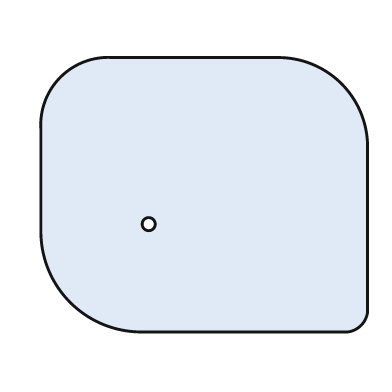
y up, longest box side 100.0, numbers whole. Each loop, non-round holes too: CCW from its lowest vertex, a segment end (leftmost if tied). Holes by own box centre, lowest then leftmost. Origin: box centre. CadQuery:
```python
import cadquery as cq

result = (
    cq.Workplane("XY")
    .moveTo(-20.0, -42.0)
    .lineTo(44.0, -42.0)
    .threePointArc((48.0, -40.0), (50.0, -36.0))
    .lineTo(50.0, 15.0)
    .threePointArc((42.0, 34.0), (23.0, 42.0))
    .lineTo(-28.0, 42.0)
    .threePointArc((-44.0, 36.0), (-50.0, 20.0))
    .lineTo(-50.0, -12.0)
    .threePointArc((-41.0, -33.0), (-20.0, -42.0))
    .close()
    .moveTo(-17.0, -9.0)
    .circle(2.0)
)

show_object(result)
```